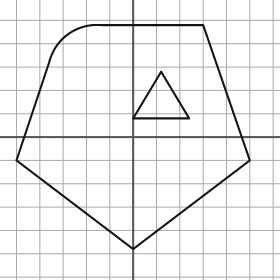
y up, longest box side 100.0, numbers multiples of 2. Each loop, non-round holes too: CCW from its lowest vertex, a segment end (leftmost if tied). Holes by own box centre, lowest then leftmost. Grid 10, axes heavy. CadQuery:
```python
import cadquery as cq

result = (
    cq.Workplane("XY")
    .moveTo(0.0, -48.0)
    .lineTo(50.0, -10.0)
    .lineTo(30.0, 48.0)
    .lineTo(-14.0, 48.0)
    .threePointArc((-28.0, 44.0), (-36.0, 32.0))
    .lineTo(-50.0, -10.0)
    .close()
    .moveTo(0.0, 8.0)
    .lineTo(24.0, 8.0)
    .lineTo(12.0, 28.0)
    .close()
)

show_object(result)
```